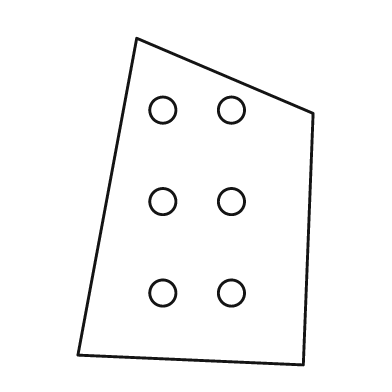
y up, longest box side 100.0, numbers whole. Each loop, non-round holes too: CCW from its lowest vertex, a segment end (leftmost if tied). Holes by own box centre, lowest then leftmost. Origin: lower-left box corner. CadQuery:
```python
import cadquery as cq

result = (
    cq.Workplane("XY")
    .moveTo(69.0, 0.0)
    .lineTo(72.0, 77.0)
    .lineTo(18.0, 100.0)
    .lineTo(0.0, 3.0)
    .close()
    .moveTo(26.0, 22.0)
    .circle(4.0)
    .moveTo(47.0, 22.0)
    .circle(4.0)
    .moveTo(26.0, 50.0)
    .circle(4.0)
    .moveTo(47.0, 50.0)
    .circle(4.0)
    .moveTo(26.0, 78.0)
    .circle(4.0)
    .moveTo(47.0, 78.0)
    .circle(4.0)
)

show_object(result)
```